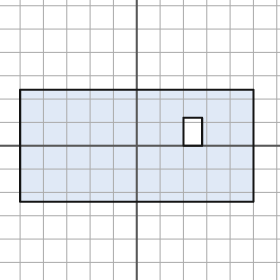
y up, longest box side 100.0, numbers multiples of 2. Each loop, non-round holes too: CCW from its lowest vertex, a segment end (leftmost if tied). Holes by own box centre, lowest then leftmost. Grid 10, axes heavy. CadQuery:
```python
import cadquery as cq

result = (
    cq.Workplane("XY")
    .moveTo(-50.0, -24.0)
    .lineTo(50.0, -24.0)
    .lineTo(50.0, 24.0)
    .lineTo(-50.0, 24.0)
    .close()
    .moveTo(20.0, 0.0)
    .lineTo(28.0, 0.0)
    .lineTo(28.0, 12.0)
    .lineTo(20.0, 12.0)
    .close()
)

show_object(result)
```